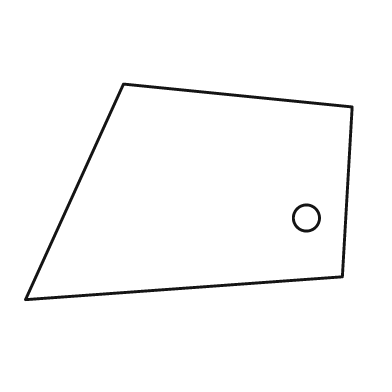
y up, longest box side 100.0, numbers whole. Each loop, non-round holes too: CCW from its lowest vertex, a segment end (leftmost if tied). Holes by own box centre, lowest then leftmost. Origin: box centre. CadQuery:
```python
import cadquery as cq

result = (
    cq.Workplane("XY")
    .moveTo(-50.0, -33.0)
    .lineTo(47.0, -26.0)
    .lineTo(50.0, 26.0)
    .lineTo(-20.0, 33.0)
    .close()
    .moveTo(36.0, -8.0)
    .circle(4.0)
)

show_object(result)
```